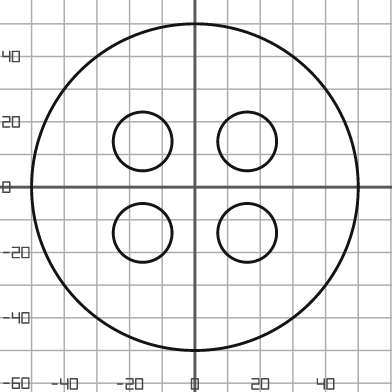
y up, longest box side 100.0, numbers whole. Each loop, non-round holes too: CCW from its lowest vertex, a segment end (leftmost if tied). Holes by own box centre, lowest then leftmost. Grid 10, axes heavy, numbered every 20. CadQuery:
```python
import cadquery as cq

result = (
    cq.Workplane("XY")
    .moveTo(0.0, 0.0)
    .circle(50.0)
    .moveTo(-16.0, -14.0)
    .circle(9.0)
    .moveTo(16.0, -14.0)
    .circle(9.0)
    .moveTo(-16.0, 14.0)
    .circle(9.0)
    .moveTo(16.0, 14.0)
    .circle(9.0)
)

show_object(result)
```